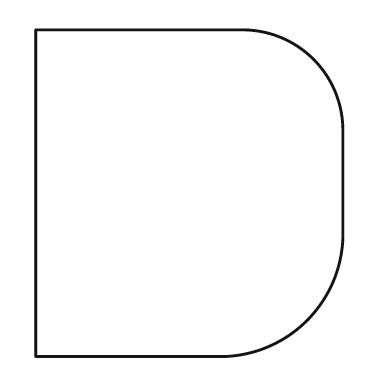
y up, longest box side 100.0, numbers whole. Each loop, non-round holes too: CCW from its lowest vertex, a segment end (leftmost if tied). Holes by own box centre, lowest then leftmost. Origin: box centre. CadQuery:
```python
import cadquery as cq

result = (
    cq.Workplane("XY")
    .moveTo(-47.0, -50.0)
    .lineTo(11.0, -50.0)
    .threePointArc((36.0, -39.0), (47.0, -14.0))
    .lineTo(47.0, 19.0)
    .threePointArc((38.0, 41.0), (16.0, 50.0))
    .lineTo(-47.0, 50.0)
    .close()
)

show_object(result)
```